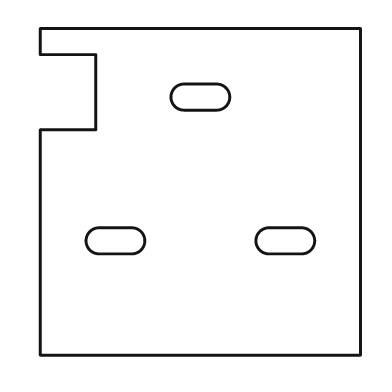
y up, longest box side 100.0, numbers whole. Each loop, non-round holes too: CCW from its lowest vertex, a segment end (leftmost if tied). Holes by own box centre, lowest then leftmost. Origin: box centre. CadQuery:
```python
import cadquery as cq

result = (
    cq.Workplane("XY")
    .moveTo(-49.0, -50.0)
    .lineTo(49.0, -50.0)
    .lineTo(49.0, 50.0)
    .lineTo(-49.0, 50.0)
    .lineTo(-49.0, 42.0)
    .lineTo(-32.0, 42.0)
    .lineTo(-32.0, 19.0)
    .lineTo(-49.0, 19.0)
    .close()
    .moveTo(-31.0, -19.0)
    .lineTo(-21.0, -19.0)
    .threePointArc((-17.0, -15.0), (-21.0, -11.0))
    .lineTo(-31.0, -11.0)
    .threePointArc((-35.0, -15.0), (-31.0, -19.0))
    .close()
    .moveTo(21.0, -19.0)
    .lineTo(31.0, -19.0)
    .threePointArc((35.0, -15.0), (31.0, -11.0))
    .lineTo(21.0, -11.0)
    .threePointArc((17.0, -15.0), (21.0, -19.0))
    .close()
    .moveTo(-5.0, 25.0)
    .lineTo(5.0, 25.0)
    .threePointArc((9.0, 29.0), (5.0, 33.0))
    .lineTo(-5.0, 33.0)
    .threePointArc((-9.0, 29.0), (-5.0, 25.0))
    .close()
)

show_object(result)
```